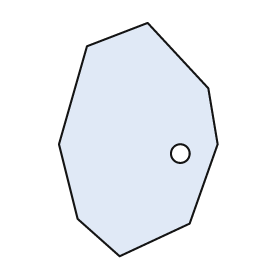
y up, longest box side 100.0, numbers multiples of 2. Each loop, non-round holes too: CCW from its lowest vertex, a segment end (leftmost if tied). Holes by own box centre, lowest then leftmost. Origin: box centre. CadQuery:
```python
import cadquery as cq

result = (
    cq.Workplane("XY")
    .moveTo(-8.0, -50.0)
    .lineTo(22.0, -36.0)
    .lineTo(34.0, -2.0)
    .lineTo(30.0, 22.0)
    .lineTo(4.0, 50.0)
    .lineTo(-22.0, 40.0)
    .lineTo(-34.0, -2.0)
    .lineTo(-26.0, -34.0)
    .close()
    .moveTo(18.0, -6.0)
    .circle(4.0)
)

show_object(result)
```